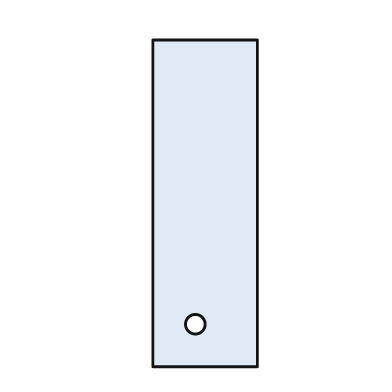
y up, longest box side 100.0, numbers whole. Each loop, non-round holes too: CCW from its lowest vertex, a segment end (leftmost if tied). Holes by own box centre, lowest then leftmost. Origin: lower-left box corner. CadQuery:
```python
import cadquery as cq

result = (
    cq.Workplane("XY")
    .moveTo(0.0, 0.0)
    .lineTo(32.0, 0.0)
    .lineTo(32.0, 100.0)
    .lineTo(0.0, 100.0)
    .close()
    .moveTo(13.0, 13.0)
    .circle(3.0)
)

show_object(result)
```